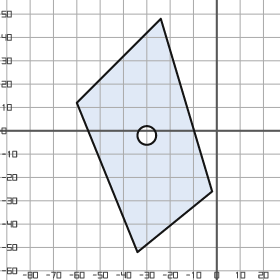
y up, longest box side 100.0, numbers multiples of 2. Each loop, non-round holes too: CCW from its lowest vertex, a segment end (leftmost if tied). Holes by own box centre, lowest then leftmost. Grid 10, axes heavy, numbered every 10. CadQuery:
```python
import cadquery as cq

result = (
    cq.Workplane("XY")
    .moveTo(-34.0, -52.0)
    .lineTo(-2.0, -26.0)
    .lineTo(-24.0, 48.0)
    .lineTo(-60.0, 12.0)
    .close()
    .moveTo(-30.0, -2.0)
    .circle(4.0)
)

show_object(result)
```